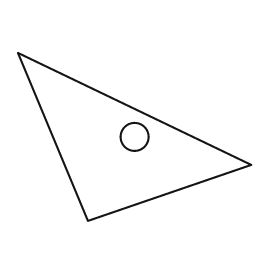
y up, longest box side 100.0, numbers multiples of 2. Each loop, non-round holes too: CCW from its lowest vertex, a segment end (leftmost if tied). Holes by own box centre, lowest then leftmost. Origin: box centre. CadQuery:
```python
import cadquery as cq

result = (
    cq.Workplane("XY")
    .moveTo(-20.0, -36.0)
    .lineTo(50.0, -12.0)
    .lineTo(-50.0, 36.0)
    .close()
    .moveTo(0.0, 0.0)
    .circle(6.0)
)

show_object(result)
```